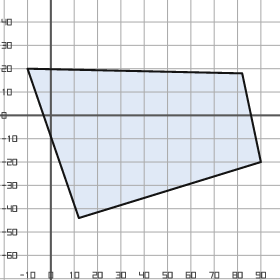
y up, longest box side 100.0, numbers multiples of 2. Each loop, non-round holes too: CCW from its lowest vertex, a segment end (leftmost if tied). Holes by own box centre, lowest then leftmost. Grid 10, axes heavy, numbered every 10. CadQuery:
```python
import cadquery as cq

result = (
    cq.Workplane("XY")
    .moveTo(12.0, -44.0)
    .lineTo(90.0, -20.0)
    .lineTo(82.0, 18.0)
    .lineTo(-10.0, 20.0)
    .close()
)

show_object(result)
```